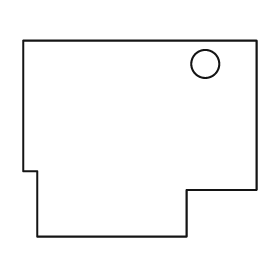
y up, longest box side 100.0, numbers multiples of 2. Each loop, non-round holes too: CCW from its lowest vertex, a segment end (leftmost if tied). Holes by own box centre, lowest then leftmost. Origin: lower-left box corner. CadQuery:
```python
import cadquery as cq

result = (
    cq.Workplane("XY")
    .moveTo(6.0, 0.0)
    .lineTo(70.0, 0.0)
    .lineTo(70.0, 20.0)
    .lineTo(100.0, 20.0)
    .lineTo(100.0, 84.0)
    .lineTo(0.0, 84.0)
    .lineTo(0.0, 28.0)
    .lineTo(6.0, 28.0)
    .close()
    .moveTo(78.0, 74.0)
    .circle(6.0)
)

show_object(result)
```